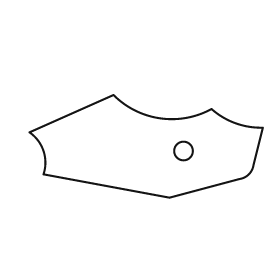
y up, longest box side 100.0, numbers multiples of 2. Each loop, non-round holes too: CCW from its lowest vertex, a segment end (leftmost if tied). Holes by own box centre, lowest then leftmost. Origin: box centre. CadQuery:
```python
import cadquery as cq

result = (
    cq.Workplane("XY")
    .moveTo(10.0, -22.0)
    .lineTo(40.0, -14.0)
    .threePointArc((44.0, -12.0), (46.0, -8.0))
    .lineTo(50.0, 8.0)
    .threePointArc((38.0, 10.0), (28.0, 16.0))
    .threePointArc((6.0, 12.0), (-14.0, 22.0))
    .lineTo(-50.0, 6.0)
    .threePointArc((-44.0, -2.0), (-44.0, -12.0))
    .close()
    .moveTo(16.0, -2.0)
    .circle(4.0)
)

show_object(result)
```